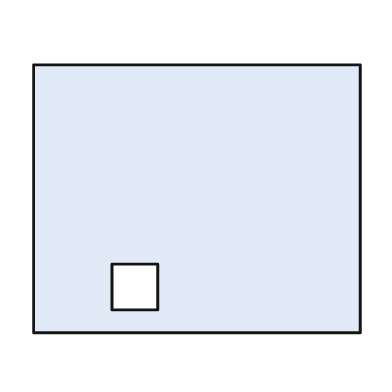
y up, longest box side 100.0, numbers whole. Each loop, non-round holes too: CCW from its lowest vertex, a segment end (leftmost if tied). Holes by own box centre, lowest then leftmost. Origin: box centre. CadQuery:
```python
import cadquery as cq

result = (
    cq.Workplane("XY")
    .moveTo(-50.0, -41.0)
    .lineTo(50.0, -41.0)
    .lineTo(50.0, 41.0)
    .lineTo(-50.0, 41.0)
    .close()
    .moveTo(-26.0, -34.0)
    .lineTo(-12.0, -34.0)
    .lineTo(-12.0, -20.0)
    .lineTo(-26.0, -20.0)
    .close()
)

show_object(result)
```